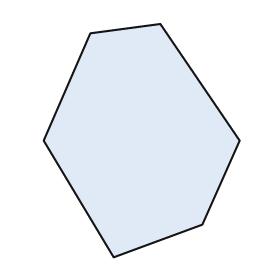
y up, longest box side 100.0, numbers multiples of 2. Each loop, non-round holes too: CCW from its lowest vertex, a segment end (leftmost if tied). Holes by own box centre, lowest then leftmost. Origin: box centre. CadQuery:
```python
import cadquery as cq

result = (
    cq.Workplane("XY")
    .moveTo(-12.0, -50.0)
    .lineTo(26.0, -36.0)
    .lineTo(42.0, 0.0)
    .lineTo(8.0, 50.0)
    .lineTo(-22.0, 46.0)
    .lineTo(-42.0, 0.0)
    .close()
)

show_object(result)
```